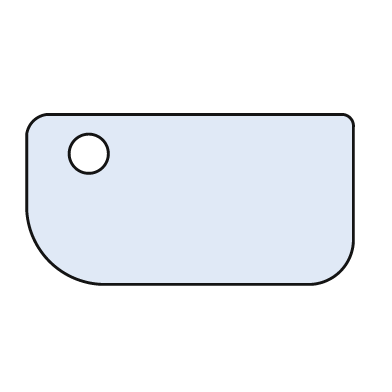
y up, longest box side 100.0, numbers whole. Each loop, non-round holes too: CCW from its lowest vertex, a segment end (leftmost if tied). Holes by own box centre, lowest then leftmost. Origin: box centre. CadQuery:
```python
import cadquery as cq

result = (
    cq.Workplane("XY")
    .moveTo(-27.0, -26.0)
    .lineTo(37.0, -26.0)
    .threePointArc((46.0, -22.0), (50.0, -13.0))
    .lineTo(50.0, 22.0)
    .threePointArc((49.0, 25.0), (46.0, 26.0))
    .lineTo(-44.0, 26.0)
    .threePointArc((-48.0, 24.0), (-50.0, 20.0))
    .lineTo(-50.0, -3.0)
    .threePointArc((-43.0, -19.0), (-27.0, -26.0))
    .close()
    .moveTo(-31.0, 14.0)
    .circle(6.0)
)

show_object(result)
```